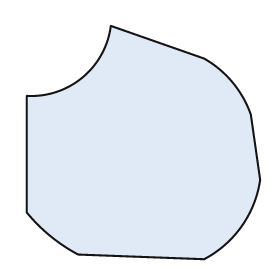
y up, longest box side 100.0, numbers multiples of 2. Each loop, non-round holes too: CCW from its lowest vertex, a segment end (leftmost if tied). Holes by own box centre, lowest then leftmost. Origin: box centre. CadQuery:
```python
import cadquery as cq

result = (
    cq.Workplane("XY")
    .moveTo(26.0, -50.0)
    .threePointArc((42.0, -36.0), (50.0, -16.0))
    .lineTo(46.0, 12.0)
    .threePointArc((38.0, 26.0), (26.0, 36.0))
    .lineTo(-14.0, 50.0)
    .threePointArc((-26.0, 28.0), (-50.0, 20.0))
    .lineTo(-50.0, -30.0)
    .threePointArc((-40.0, -40.0), (-28.0, -48.0))
    .close()
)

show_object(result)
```